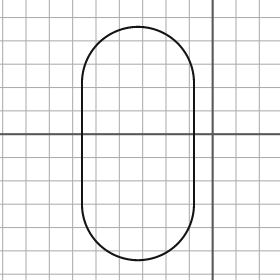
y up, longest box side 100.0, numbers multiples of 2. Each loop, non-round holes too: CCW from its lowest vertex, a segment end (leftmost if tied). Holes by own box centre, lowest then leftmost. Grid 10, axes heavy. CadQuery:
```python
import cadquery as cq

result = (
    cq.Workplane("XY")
    .moveTo(-56.0, -30.0)
    .threePointArc((-32.0, -54.0), (-8.0, -30.0))
    .lineTo(-8.0, 22.0)
    .threePointArc((-32.0, 46.0), (-56.0, 22.0))
    .close()
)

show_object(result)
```